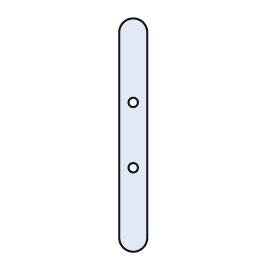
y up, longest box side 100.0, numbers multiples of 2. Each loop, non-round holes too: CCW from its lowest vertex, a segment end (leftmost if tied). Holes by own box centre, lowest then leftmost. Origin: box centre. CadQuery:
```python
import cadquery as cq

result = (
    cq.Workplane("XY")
    .moveTo(-6.0, -44.0)
    .threePointArc((0.0, -50.0), (6.0, -44.0))
    .lineTo(6.0, 44.0)
    .threePointArc((0.0, 50.0), (-6.0, 44.0))
    .close()
    .moveTo(0.0, -14.0)
    .circle(2.0)
    .moveTo(0.0, 14.0)
    .circle(2.0)
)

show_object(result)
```